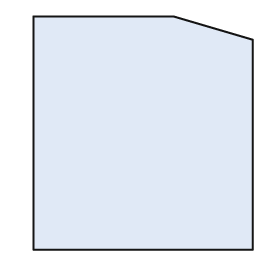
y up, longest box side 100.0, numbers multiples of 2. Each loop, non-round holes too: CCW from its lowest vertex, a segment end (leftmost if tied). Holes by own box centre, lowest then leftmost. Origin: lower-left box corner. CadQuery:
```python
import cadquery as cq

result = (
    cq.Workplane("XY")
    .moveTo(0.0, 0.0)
    .lineTo(94.0, 0.0)
    .lineTo(94.0, 90.0)
    .lineTo(60.0, 100.0)
    .lineTo(0.0, 100.0)
    .close()
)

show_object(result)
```